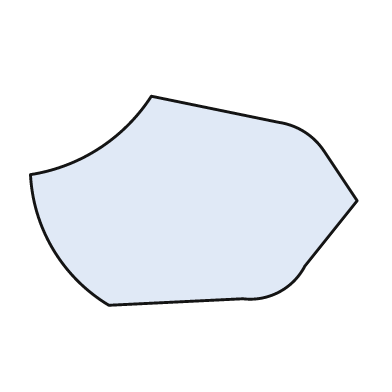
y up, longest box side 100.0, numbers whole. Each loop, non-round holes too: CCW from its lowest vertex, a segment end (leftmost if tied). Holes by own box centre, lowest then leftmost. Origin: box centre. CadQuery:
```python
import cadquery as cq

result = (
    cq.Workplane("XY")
    .moveTo(-26.0, -32.0)
    .lineTo(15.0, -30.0)
    .threePointArc((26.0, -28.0), (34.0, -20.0))
    .lineTo(50.0, 0.0)
    .lineTo(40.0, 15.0)
    .threePointArc((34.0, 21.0), (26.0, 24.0))
    .lineTo(-13.0, 32.0)
    .threePointArc((-29.0, 16.0), (-50.0, 8.0))
    .threePointArc((-43.0, -15.0), (-26.0, -32.0))
    .close()
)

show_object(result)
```